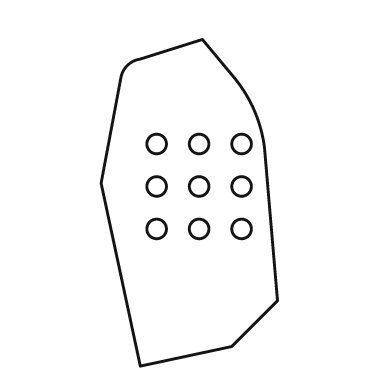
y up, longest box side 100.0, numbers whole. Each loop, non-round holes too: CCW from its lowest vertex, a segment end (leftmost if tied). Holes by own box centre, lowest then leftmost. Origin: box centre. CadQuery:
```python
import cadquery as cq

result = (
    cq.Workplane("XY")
    .moveTo(-15.0, -50.0)
    .lineTo(13.0, -44.0)
    .lineTo(27.0, -30.0)
    .lineTo(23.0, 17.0)
    .threePointArc((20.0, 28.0), (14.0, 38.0))
    .lineTo(4.0, 50.0)
    .lineTo(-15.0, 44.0)
    .threePointArc((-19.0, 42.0), (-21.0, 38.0))
    .lineTo(-27.0, 6.0)
    .close()
    .moveTo(-10.0, -8.0)
    .circle(3.0)
    .moveTo(3.0, -8.0)
    .circle(3.0)
    .moveTo(16.0, -8.0)
    .circle(3.0)
    .moveTo(-10.0, 5.0)
    .circle(3.0)
    .moveTo(3.0, 5.0)
    .circle(3.0)
    .moveTo(16.0, 5.0)
    .circle(3.0)
    .moveTo(-10.0, 18.0)
    .circle(3.0)
    .moveTo(3.0, 18.0)
    .circle(3.0)
    .moveTo(16.0, 18.0)
    .circle(3.0)
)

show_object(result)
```